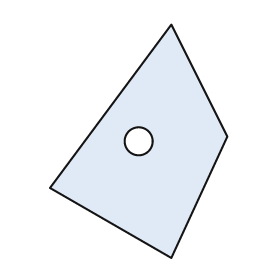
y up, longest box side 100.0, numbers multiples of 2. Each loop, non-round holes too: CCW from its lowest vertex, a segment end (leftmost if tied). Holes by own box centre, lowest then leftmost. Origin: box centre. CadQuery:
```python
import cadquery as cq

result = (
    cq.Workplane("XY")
    .moveTo(14.0, -50.0)
    .lineTo(38.0, 2.0)
    .lineTo(14.0, 50.0)
    .lineTo(-38.0, -20.0)
    .close()
    .moveTo(0.0, 0.0)
    .circle(6.0)
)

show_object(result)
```